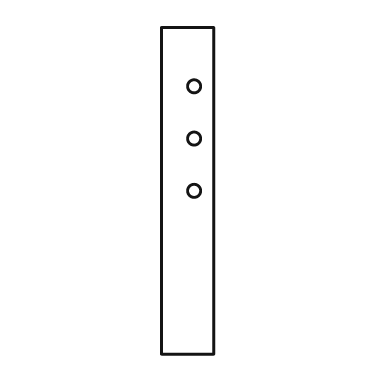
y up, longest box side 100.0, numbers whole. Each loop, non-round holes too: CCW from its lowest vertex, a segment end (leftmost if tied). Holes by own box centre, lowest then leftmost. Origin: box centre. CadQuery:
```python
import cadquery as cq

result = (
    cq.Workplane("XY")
    .moveTo(-8.0, -50.0)
    .lineTo(8.0, -50.0)
    .lineTo(8.0, 50.0)
    .lineTo(-8.0, 50.0)
    .close()
    .moveTo(2.0, 0.0)
    .circle(2.0)
    .moveTo(2.0, 16.0)
    .circle(2.0)
    .moveTo(2.0, 32.0)
    .circle(2.0)
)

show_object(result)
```